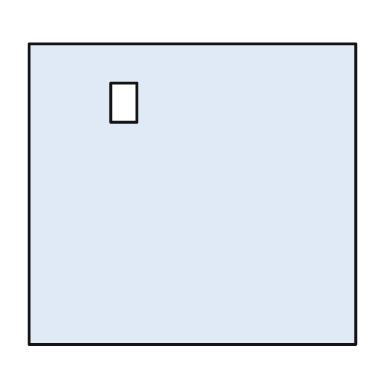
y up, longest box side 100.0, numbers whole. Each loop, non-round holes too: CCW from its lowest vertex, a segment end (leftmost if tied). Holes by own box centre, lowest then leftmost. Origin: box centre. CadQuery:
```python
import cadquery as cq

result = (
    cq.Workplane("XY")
    .moveTo(-50.0, -46.0)
    .lineTo(50.0, -46.0)
    .lineTo(50.0, 46.0)
    .lineTo(-50.0, 46.0)
    .close()
    .moveTo(-25.0, 22.0)
    .lineTo(-17.0, 22.0)
    .lineTo(-17.0, 34.0)
    .lineTo(-25.0, 34.0)
    .close()
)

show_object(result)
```